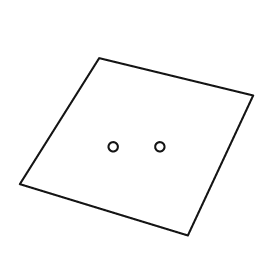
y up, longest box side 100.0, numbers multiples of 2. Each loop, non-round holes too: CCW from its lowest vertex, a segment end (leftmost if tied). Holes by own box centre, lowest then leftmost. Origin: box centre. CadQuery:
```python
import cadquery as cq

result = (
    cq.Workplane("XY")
    .moveTo(22.0, -38.0)
    .lineTo(50.0, 22.0)
    .lineTo(-16.0, 38.0)
    .lineTo(-50.0, -16.0)
    .close()
    .moveTo(-10.0, 0.0)
    .circle(2.0)
    .moveTo(10.0, 0.0)
    .circle(2.0)
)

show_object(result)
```